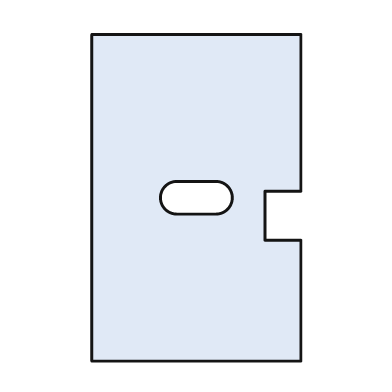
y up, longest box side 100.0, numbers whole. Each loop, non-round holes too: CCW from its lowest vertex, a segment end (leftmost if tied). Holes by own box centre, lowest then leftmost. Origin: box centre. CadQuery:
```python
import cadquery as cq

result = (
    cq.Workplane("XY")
    .moveTo(-32.0, -50.0)
    .lineTo(32.0, -50.0)
    .lineTo(32.0, -13.0)
    .lineTo(21.0, -13.0)
    .lineTo(21.0, 2.0)
    .lineTo(32.0, 2.0)
    .lineTo(32.0, 50.0)
    .lineTo(-32.0, 50.0)
    .close()
    .moveTo(-6.0, -5.0)
    .lineTo(6.0, -5.0)
    .threePointArc((11.0, 0.0), (6.0, 5.0))
    .lineTo(-6.0, 5.0)
    .threePointArc((-11.0, 0.0), (-6.0, -5.0))
    .close()
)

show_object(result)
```